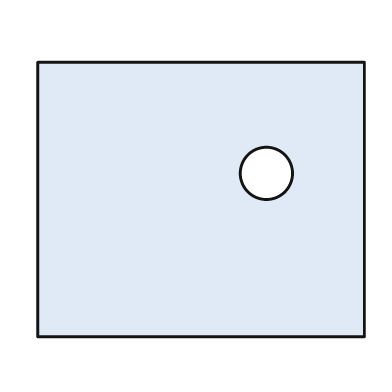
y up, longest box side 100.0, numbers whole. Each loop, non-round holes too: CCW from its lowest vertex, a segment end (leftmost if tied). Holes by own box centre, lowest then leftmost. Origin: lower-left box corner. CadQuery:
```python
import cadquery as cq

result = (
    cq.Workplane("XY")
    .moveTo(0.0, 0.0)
    .lineTo(100.0, 0.0)
    .lineTo(100.0, 84.0)
    .lineTo(0.0, 84.0)
    .close()
    .moveTo(70.0, 50.0)
    .circle(8.0)
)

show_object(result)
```